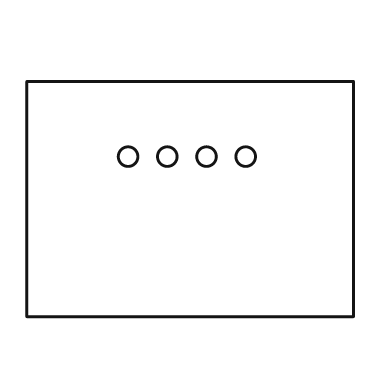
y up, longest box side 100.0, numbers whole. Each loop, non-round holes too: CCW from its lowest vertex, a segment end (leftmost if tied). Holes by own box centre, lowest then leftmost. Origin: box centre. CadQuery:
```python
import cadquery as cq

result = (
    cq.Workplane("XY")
    .moveTo(-50.0, -36.0)
    .lineTo(50.0, -36.0)
    .lineTo(50.0, 36.0)
    .lineTo(-50.0, 36.0)
    .close()
    .moveTo(-19.0, 13.0)
    .circle(3.0)
    .moveTo(-7.0, 13.0)
    .circle(3.0)
    .moveTo(5.0, 13.0)
    .circle(3.0)
    .moveTo(17.0, 13.0)
    .circle(3.0)
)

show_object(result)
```